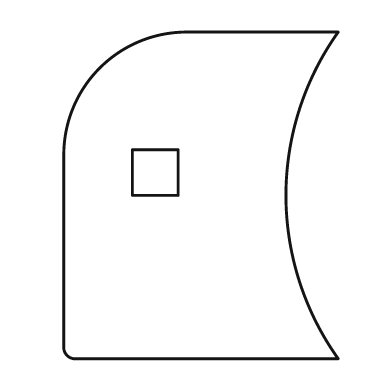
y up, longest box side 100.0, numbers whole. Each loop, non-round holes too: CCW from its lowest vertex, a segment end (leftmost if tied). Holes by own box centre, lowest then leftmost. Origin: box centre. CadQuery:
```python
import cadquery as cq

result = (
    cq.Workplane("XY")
    .moveTo(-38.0, -50.0)
    .lineTo(42.0, -50.0)
    .threePointArc((26.0, 0.0), (42.0, 50.0))
    .lineTo(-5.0, 50.0)
    .threePointArc((-31.0, 39.0), (-42.0, 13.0))
    .lineTo(-42.0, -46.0)
    .threePointArc((-41.0, -49.0), (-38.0, -50.0))
    .close()
    .moveTo(-21.0, 0.0)
    .lineTo(-7.0, 0.0)
    .lineTo(-7.0, 14.0)
    .lineTo(-21.0, 14.0)
    .close()
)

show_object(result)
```